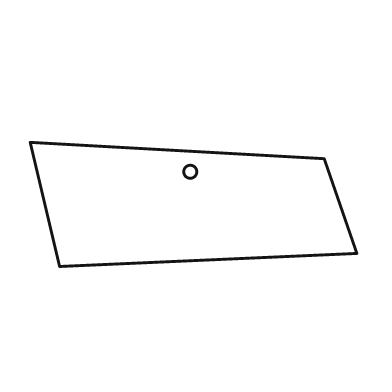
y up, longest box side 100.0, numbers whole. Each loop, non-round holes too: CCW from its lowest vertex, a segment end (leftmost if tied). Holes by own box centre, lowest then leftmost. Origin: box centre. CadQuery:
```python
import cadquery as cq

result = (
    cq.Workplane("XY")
    .moveTo(-41.0, -19.0)
    .lineTo(50.0, -15.0)
    .lineTo(40.0, 14.0)
    .lineTo(-50.0, 19.0)
    .close()
    .moveTo(-1.0, 10.0)
    .circle(2.0)
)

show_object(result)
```